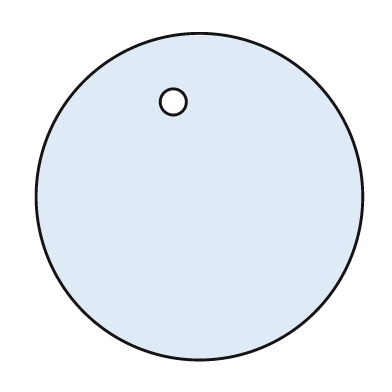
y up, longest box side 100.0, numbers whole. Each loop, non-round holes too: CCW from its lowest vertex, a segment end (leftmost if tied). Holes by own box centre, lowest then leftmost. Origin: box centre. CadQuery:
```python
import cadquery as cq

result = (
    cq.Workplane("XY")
    .moveTo(0.0, 0.0)
    .circle(50.0)
    .moveTo(-8.0, 29.0)
    .circle(4.0)
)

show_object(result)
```